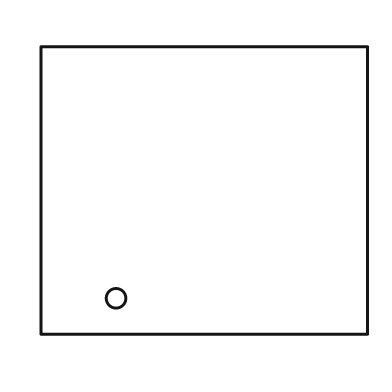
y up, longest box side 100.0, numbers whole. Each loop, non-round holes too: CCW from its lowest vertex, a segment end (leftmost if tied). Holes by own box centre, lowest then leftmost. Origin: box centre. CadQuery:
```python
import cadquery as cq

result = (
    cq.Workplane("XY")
    .moveTo(-50.0, -44.0)
    .lineTo(50.0, -44.0)
    .lineTo(50.0, 44.0)
    .lineTo(-50.0, 44.0)
    .close()
    .moveTo(-27.0, -33.0)
    .circle(3.0)
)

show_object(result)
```